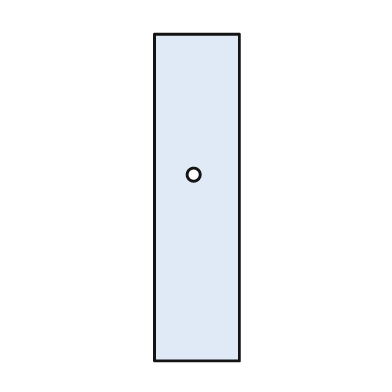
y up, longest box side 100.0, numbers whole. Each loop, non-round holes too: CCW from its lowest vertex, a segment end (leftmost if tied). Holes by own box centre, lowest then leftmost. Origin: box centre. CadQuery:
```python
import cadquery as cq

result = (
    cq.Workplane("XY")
    .moveTo(-13.0, -50.0)
    .lineTo(13.0, -50.0)
    .lineTo(13.0, 50.0)
    .lineTo(-13.0, 50.0)
    .close()
    .moveTo(-1.0, 7.0)
    .circle(2.0)
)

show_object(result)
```